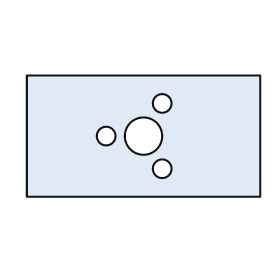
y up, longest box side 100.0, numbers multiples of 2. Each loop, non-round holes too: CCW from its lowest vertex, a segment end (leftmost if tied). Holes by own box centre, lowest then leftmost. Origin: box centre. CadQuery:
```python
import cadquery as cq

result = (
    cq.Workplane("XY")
    .moveTo(-50.0, -26.0)
    .lineTo(50.0, -26.0)
    .lineTo(50.0, 26.0)
    .lineTo(-50.0, 26.0)
    .close()
    .moveTo(8.0, -14.0)
    .circle(4.0)
    .moveTo(-16.0, 0.0)
    .circle(4.0)
    .moveTo(0.0, 0.0)
    .circle(8.0)
    .moveTo(8.0, 14.0)
    .circle(4.0)
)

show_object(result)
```